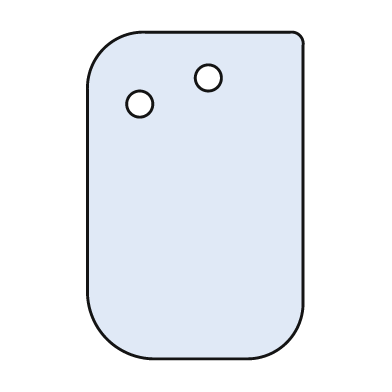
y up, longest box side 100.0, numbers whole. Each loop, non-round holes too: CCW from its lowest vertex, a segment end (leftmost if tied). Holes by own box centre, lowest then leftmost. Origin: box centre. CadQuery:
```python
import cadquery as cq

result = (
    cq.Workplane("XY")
    .moveTo(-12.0, -50.0)
    .lineTo(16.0, -50.0)
    .threePointArc((28.0, -45.0), (33.0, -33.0))
    .lineTo(33.0, 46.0)
    .threePointArc((32.0, 49.0), (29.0, 50.0))
    .lineTo(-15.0, 50.0)
    .threePointArc((-28.0, 45.0), (-33.0, 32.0))
    .lineTo(-33.0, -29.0)
    .threePointArc((-27.0, -44.0), (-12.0, -50.0))
    .close()
    .moveTo(-17.0, 28.0)
    .circle(4.0)
    .moveTo(4.0, 36.0)
    .circle(4.0)
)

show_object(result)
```